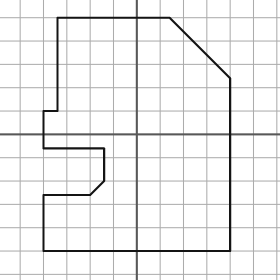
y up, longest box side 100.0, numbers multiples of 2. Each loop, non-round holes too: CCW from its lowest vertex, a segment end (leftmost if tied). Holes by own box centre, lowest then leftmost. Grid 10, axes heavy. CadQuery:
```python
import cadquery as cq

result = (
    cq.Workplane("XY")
    .moveTo(-40.0, -50.0)
    .lineTo(40.0, -50.0)
    .lineTo(40.0, 24.0)
    .lineTo(14.0, 50.0)
    .lineTo(-34.0, 50.0)
    .lineTo(-34.0, 10.0)
    .lineTo(-40.0, 10.0)
    .lineTo(-40.0, -6.0)
    .lineTo(-14.0, -6.0)
    .lineTo(-14.0, -20.0)
    .lineTo(-20.0, -26.0)
    .lineTo(-40.0, -26.0)
    .close()
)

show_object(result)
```